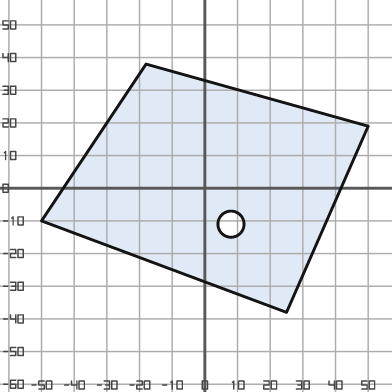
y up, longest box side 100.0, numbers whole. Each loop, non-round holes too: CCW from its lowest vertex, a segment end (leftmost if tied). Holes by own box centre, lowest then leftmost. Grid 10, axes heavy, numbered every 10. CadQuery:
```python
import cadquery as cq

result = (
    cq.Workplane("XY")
    .moveTo(25.0, -38.0)
    .lineTo(50.0, 19.0)
    .lineTo(-18.0, 38.0)
    .lineTo(-50.0, -10.0)
    .close()
    .moveTo(8.0, -11.0)
    .circle(4.0)
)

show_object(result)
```